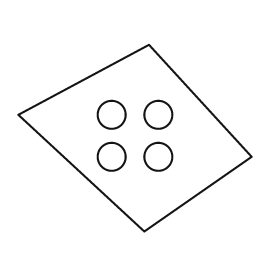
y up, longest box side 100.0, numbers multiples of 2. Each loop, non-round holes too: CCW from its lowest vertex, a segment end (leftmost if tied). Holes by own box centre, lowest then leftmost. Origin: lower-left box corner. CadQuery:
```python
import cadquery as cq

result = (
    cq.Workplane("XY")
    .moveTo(54.0, 0.0)
    .lineTo(100.0, 32.0)
    .lineTo(56.0, 80.0)
    .lineTo(0.0, 50.0)
    .close()
    .moveTo(40.0, 32.0)
    .circle(6.0)
    .moveTo(60.0, 32.0)
    .circle(6.0)
    .moveTo(40.0, 50.0)
    .circle(6.0)
    .moveTo(60.0, 50.0)
    .circle(6.0)
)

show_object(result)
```